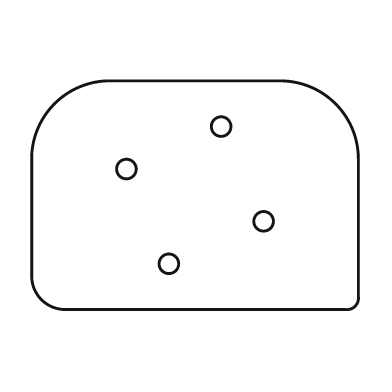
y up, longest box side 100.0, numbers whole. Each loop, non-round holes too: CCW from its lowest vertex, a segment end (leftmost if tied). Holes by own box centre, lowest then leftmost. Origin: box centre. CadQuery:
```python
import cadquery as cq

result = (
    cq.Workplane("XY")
    .moveTo(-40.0, -35.0)
    .lineTo(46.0, -35.0)
    .threePointArc((49.0, -34.0), (50.0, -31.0))
    .lineTo(50.0, 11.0)
    .threePointArc((43.0, 28.0), (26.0, 35.0))
    .lineTo(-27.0, 35.0)
    .threePointArc((-43.0, 28.0), (-50.0, 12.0))
    .lineTo(-50.0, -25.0)
    .threePointArc((-47.0, -32.0), (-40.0, -35.0))
    .close()
    .moveTo(-8.0, -21.0)
    .circle(3.0)
    .moveTo(21.0, -8.0)
    .circle(3.0)
    .moveTo(-21.0, 8.0)
    .circle(3.0)
    .moveTo(8.0, 21.0)
    .circle(3.0)
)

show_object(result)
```